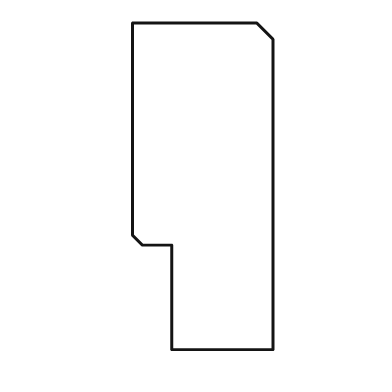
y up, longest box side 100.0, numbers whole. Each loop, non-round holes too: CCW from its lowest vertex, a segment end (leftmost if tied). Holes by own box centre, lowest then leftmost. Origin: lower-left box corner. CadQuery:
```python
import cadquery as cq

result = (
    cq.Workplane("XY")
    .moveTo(12.0, 0.0)
    .lineTo(43.0, 0.0)
    .lineTo(43.0, 95.0)
    .lineTo(38.0, 100.0)
    .lineTo(0.0, 100.0)
    .lineTo(0.0, 35.0)
    .lineTo(3.0, 32.0)
    .lineTo(12.0, 32.0)
    .close()
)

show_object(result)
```